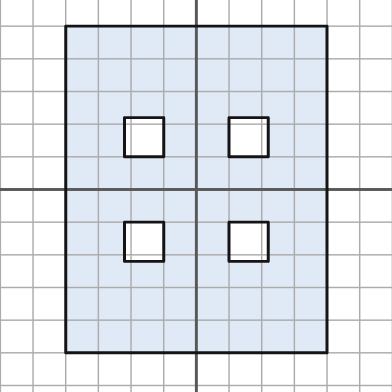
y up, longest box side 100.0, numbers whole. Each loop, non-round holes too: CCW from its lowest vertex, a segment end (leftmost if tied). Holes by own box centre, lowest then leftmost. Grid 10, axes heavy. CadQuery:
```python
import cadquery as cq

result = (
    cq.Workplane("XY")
    .moveTo(-40.0, -50.0)
    .lineTo(40.0, -50.0)
    .lineTo(40.0, 50.0)
    .lineTo(-40.0, 50.0)
    .close()
    .moveTo(-22.0, -22.0)
    .lineTo(-10.0, -22.0)
    .lineTo(-10.0, -10.0)
    .lineTo(-22.0, -10.0)
    .close()
    .moveTo(10.0, -22.0)
    .lineTo(22.0, -22.0)
    .lineTo(22.0, -10.0)
    .lineTo(10.0, -10.0)
    .close()
    .moveTo(-22.0, 10.0)
    .lineTo(-10.0, 10.0)
    .lineTo(-10.0, 22.0)
    .lineTo(-22.0, 22.0)
    .close()
    .moveTo(10.0, 10.0)
    .lineTo(22.0, 10.0)
    .lineTo(22.0, 22.0)
    .lineTo(10.0, 22.0)
    .close()
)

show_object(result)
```